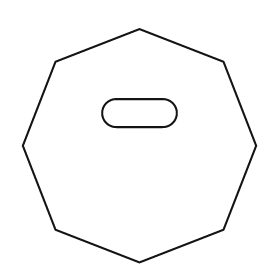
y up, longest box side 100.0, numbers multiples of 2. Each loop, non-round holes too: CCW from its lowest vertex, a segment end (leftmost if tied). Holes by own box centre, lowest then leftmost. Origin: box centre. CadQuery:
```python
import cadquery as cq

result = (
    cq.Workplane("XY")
    .moveTo(0.0, -50.0)
    .lineTo(36.0, -36.0)
    .lineTo(50.0, 0.0)
    .lineTo(36.0, 36.0)
    .lineTo(0.0, 50.0)
    .lineTo(-36.0, 36.0)
    .lineTo(-50.0, 0.0)
    .lineTo(-36.0, -36.0)
    .close()
    .moveTo(-10.0, 8.0)
    .lineTo(10.0, 8.0)
    .threePointArc((16.0, 14.0), (10.0, 20.0))
    .lineTo(-10.0, 20.0)
    .threePointArc((-16.0, 14.0), (-10.0, 8.0))
    .close()
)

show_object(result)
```